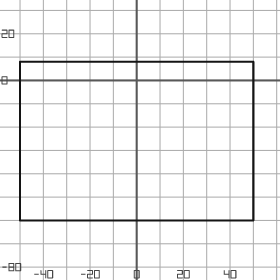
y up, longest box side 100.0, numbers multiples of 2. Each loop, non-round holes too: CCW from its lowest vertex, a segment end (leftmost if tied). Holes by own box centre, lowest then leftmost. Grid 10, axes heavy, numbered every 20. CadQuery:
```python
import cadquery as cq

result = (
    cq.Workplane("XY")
    .moveTo(-50.0, -60.0)
    .lineTo(50.0, -60.0)
    .lineTo(50.0, 8.0)
    .lineTo(-50.0, 8.0)
    .close()
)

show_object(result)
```